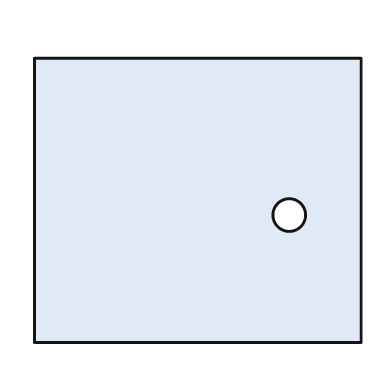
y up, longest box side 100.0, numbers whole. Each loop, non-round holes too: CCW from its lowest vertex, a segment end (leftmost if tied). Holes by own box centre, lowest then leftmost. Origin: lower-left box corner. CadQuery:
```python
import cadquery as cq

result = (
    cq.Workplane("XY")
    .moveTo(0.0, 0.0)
    .lineTo(100.0, 0.0)
    .lineTo(100.0, 87.0)
    .lineTo(0.0, 87.0)
    .close()
    .moveTo(78.0, 39.0)
    .circle(5.0)
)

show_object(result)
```